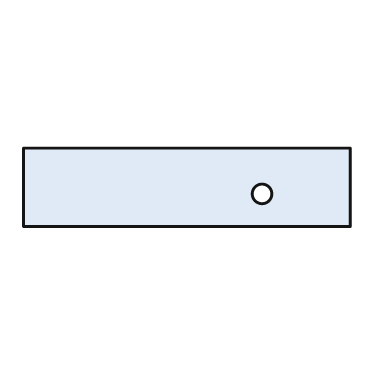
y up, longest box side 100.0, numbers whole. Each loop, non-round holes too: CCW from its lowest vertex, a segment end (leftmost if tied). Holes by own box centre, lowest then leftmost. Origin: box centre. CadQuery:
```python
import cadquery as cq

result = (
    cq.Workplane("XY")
    .moveTo(-50.0, -12.0)
    .lineTo(50.0, -12.0)
    .lineTo(50.0, 12.0)
    .lineTo(-50.0, 12.0)
    .close()
    .moveTo(23.0, -2.0)
    .circle(3.0)
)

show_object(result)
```